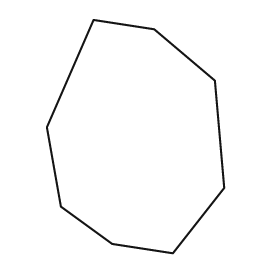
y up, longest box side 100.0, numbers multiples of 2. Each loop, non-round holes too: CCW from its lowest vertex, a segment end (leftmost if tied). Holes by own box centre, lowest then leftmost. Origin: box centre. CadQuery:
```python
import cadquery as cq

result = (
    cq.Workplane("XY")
    .moveTo(16.0, -50.0)
    .lineTo(38.0, -22.0)
    .lineTo(34.0, 24.0)
    .lineTo(8.0, 46.0)
    .lineTo(-18.0, 50.0)
    .lineTo(-38.0, 4.0)
    .lineTo(-32.0, -30.0)
    .lineTo(-10.0, -46.0)
    .close()
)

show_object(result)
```